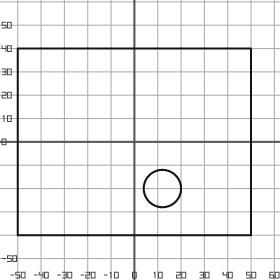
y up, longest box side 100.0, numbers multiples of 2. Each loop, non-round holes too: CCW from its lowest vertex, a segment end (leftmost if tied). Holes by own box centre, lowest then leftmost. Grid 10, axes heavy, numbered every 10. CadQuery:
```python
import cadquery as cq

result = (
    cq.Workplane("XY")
    .moveTo(-50.0, -40.0)
    .lineTo(50.0, -40.0)
    .lineTo(50.0, 40.0)
    .lineTo(-50.0, 40.0)
    .close()
    .moveTo(12.0, -20.0)
    .circle(8.0)
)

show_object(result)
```